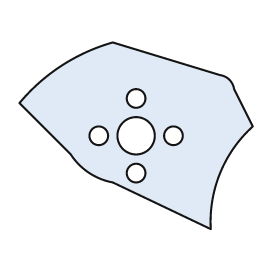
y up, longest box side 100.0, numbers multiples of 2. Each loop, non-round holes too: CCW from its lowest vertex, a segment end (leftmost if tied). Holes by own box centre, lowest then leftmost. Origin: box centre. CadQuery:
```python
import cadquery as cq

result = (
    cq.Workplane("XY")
    .moveTo(32.0, -40.0)
    .threePointArc((36.0, -16.0), (50.0, 4.0))
    .lineTo(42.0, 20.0)
    .threePointArc((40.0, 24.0), (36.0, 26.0))
    .lineTo(-10.0, 40.0)
    .threePointArc((-32.0, 30.0), (-50.0, 14.0))
    .lineTo(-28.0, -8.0)
    .threePointArc((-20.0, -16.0), (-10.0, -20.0))
    .close()
    .moveTo(0.0, -16.0)
    .circle(4.0)
    .moveTo(-16.0, 0.0)
    .circle(4.0)
    .moveTo(0.0, 0.0)
    .circle(8.0)
    .moveTo(16.0, 0.0)
    .circle(4.0)
    .moveTo(0.0, 16.0)
    .circle(4.0)
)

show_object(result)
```